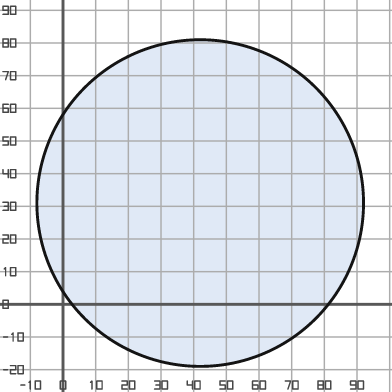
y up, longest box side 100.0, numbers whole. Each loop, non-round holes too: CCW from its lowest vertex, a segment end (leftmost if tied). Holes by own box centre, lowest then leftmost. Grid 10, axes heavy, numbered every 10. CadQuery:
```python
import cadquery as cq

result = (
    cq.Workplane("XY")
    .moveTo(42.0, 31.0)
    .circle(50.0)
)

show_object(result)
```